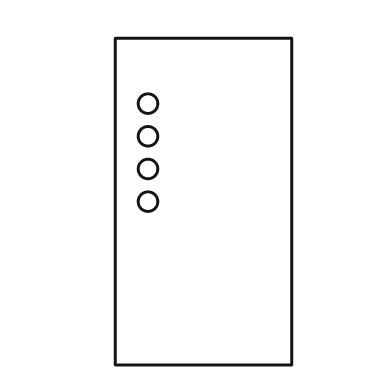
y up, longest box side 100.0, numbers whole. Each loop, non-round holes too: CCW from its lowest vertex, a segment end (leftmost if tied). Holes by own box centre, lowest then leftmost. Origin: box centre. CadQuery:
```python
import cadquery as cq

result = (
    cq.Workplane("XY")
    .moveTo(-27.0, -50.0)
    .lineTo(27.0, -50.0)
    .lineTo(27.0, 50.0)
    .lineTo(-27.0, 50.0)
    .close()
    .moveTo(-17.0, 0.0)
    .circle(3.0)
    .moveTo(-17.0, 10.0)
    .circle(3.0)
    .moveTo(-17.0, 20.0)
    .circle(3.0)
    .moveTo(-17.0, 30.0)
    .circle(3.0)
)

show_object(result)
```